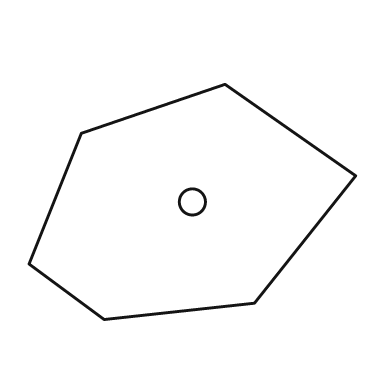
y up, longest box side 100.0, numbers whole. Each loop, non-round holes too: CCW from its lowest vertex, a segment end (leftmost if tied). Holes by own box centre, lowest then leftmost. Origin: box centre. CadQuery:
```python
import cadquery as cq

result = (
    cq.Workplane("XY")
    .moveTo(-27.0, -36.0)
    .lineTo(19.0, -31.0)
    .lineTo(50.0, 8.0)
    .lineTo(10.0, 36.0)
    .lineTo(-34.0, 21.0)
    .lineTo(-50.0, -19.0)
    .close()
    .moveTo(0.0, 0.0)
    .circle(4.0)
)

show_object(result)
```